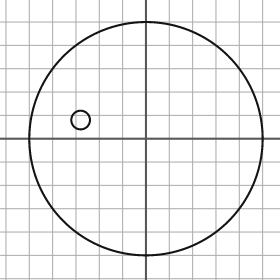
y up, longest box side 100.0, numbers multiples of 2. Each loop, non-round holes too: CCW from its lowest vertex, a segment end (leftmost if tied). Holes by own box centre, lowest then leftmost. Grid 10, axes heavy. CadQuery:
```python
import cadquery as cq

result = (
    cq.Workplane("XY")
    .moveTo(0.0, 0.0)
    .circle(50.0)
    .moveTo(-28.0, 8.0)
    .circle(4.0)
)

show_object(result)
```